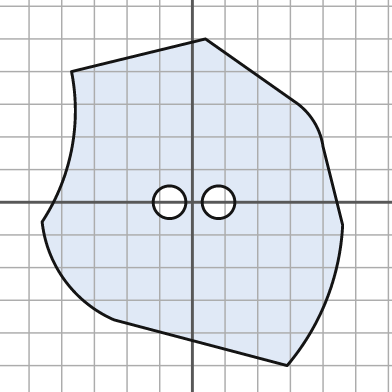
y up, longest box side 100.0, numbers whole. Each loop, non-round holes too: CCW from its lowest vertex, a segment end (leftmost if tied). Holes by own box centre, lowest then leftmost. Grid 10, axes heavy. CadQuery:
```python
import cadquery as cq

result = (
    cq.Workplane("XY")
    .moveTo(29.0, -50.0)
    .threePointArc((41.0, -30.0), (46.0, -7.0))
    .lineTo(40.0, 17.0)
    .threePointArc((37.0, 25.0), (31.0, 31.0))
    .lineTo(4.0, 50.0)
    .lineTo(-37.0, 40.0)
    .threePointArc((-37.0, 16.0), (-46.0, -6.0))
    .threePointArc((-39.0, -24.0), (-24.0, -36.0))
    .close()
    .moveTo(-7.0, 0.0)
    .circle(5.0)
    .moveTo(8.0, 0.0)
    .circle(5.0)
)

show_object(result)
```